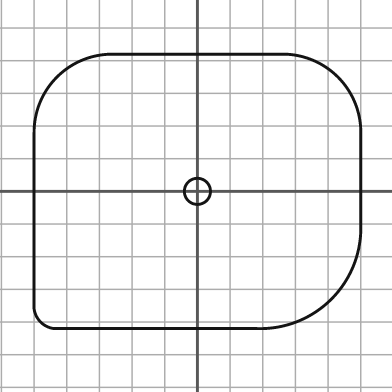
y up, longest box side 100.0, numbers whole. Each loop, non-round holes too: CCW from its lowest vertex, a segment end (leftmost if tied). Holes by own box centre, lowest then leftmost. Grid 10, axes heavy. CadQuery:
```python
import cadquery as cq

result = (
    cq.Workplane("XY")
    .moveTo(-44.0, -42.0)
    .lineTo(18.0, -42.0)
    .threePointArc((41.0, -33.0), (50.0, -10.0))
    .lineTo(50.0, 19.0)
    .threePointArc((43.0, 35.0), (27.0, 42.0))
    .lineTo(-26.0, 42.0)
    .threePointArc((-43.0, 35.0), (-50.0, 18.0))
    .lineTo(-50.0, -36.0)
    .threePointArc((-48.0, -40.0), (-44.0, -42.0))
    .close()
    .moveTo(0.0, 0.0)
    .circle(4.0)
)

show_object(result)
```